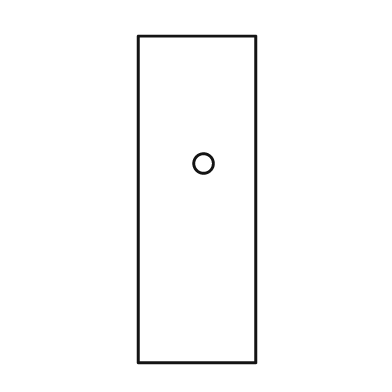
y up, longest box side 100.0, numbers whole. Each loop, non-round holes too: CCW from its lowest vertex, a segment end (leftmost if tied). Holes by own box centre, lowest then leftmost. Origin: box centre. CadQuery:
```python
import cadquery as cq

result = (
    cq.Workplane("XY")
    .moveTo(-18.0, -50.0)
    .lineTo(18.0, -50.0)
    .lineTo(18.0, 50.0)
    .lineTo(-18.0, 50.0)
    .close()
    .moveTo(2.0, 11.0)
    .circle(3.0)
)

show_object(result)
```